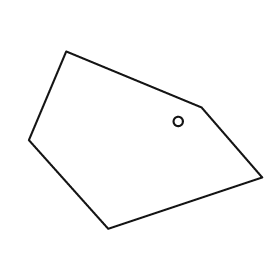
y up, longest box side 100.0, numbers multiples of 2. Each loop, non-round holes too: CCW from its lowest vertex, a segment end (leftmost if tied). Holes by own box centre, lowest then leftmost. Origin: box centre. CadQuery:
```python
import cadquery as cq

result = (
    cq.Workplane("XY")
    .moveTo(-16.0, -38.0)
    .lineTo(50.0, -16.0)
    .lineTo(24.0, 14.0)
    .lineTo(-34.0, 38.0)
    .lineTo(-50.0, 0.0)
    .close()
    .moveTo(14.0, 8.0)
    .circle(2.0)
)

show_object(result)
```